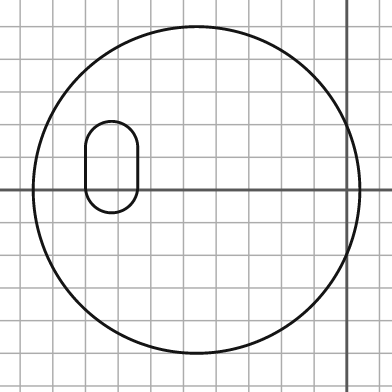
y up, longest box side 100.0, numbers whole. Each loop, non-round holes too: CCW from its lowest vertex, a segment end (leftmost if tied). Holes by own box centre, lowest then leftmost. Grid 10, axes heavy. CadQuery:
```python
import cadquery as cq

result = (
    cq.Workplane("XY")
    .moveTo(-46.0, 0.0)
    .circle(50.0)
    .moveTo(-80.0, 1.0)
    .threePointArc((-72.0, -7.0), (-64.0, 1.0))
    .lineTo(-64.0, 13.0)
    .threePointArc((-72.0, 21.0), (-80.0, 13.0))
    .close()
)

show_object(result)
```